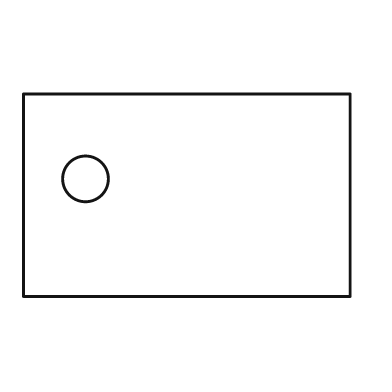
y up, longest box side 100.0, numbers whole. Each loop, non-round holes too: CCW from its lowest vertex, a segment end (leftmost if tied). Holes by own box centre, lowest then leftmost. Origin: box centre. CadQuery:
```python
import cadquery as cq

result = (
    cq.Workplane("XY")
    .moveTo(-50.0, -31.0)
    .lineTo(50.0, -31.0)
    .lineTo(50.0, 31.0)
    .lineTo(-50.0, 31.0)
    .close()
    .moveTo(-31.0, 5.0)
    .circle(7.0)
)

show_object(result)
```